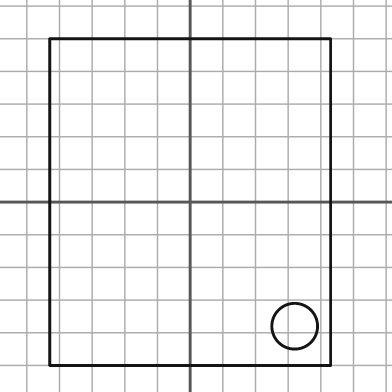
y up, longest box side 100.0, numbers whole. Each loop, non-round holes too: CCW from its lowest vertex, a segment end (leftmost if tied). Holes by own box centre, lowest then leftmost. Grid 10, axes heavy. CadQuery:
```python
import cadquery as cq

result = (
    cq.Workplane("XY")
    .moveTo(-43.0, -50.0)
    .lineTo(43.0, -50.0)
    .lineTo(43.0, 50.0)
    .lineTo(-43.0, 50.0)
    .close()
    .moveTo(32.0, -38.0)
    .circle(7.0)
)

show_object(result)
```